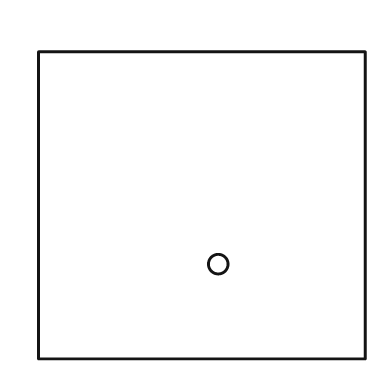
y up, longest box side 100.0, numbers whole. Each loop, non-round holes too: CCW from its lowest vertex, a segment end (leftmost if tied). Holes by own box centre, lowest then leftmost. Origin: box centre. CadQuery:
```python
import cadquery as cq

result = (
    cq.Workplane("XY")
    .moveTo(-50.0, -47.0)
    .lineTo(50.0, -47.0)
    .lineTo(50.0, 47.0)
    .lineTo(-50.0, 47.0)
    .close()
    .moveTo(5.0, -18.0)
    .circle(3.0)
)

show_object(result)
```